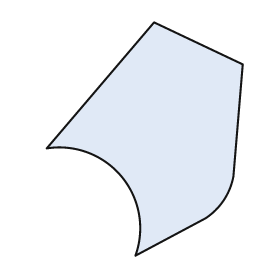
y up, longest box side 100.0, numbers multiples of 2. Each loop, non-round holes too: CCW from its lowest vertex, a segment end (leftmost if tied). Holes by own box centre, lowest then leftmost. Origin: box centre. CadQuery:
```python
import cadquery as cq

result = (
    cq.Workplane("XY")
    .moveTo(-4.0, -50.0)
    .lineTo(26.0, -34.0)
    .threePointArc((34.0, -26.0), (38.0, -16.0))
    .lineTo(42.0, 32.0)
    .lineTo(4.0, 50.0)
    .lineTo(-42.0, -4.0)
    .threePointArc((-10.0, -16.0), (-4.0, -50.0))
    .close()
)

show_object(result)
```